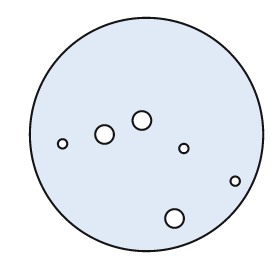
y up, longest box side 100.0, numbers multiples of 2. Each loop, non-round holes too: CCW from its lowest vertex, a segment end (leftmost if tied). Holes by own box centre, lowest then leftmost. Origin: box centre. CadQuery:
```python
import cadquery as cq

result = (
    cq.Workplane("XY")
    .moveTo(0.0, 0.0)
    .circle(50.0)
    .moveTo(12.0, -36.0)
    .circle(4.0)
    .moveTo(38.0, -20.0)
    .circle(2.0)
    .moveTo(16.0, -6.0)
    .circle(2.0)
    .moveTo(-36.0, -4.0)
    .circle(2.0)
    .moveTo(-18.0, 0.0)
    .circle(4.0)
    .moveTo(-2.0, 6.0)
    .circle(4.0)
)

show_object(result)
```